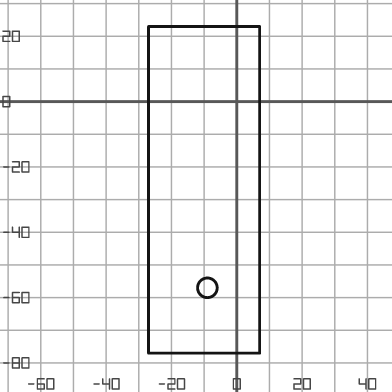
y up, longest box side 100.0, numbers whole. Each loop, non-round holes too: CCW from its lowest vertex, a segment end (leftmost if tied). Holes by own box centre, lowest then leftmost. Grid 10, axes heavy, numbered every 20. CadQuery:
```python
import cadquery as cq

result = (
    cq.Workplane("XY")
    .moveTo(-27.0, -77.0)
    .lineTo(7.0, -77.0)
    .lineTo(7.0, 23.0)
    .lineTo(-27.0, 23.0)
    .close()
    .moveTo(-9.0, -57.0)
    .circle(3.0)
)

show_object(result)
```